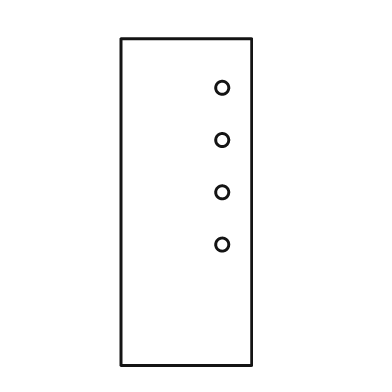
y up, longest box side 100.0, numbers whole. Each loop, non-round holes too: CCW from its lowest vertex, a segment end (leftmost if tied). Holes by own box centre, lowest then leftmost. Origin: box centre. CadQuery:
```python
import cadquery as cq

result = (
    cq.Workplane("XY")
    .moveTo(-20.0, -50.0)
    .lineTo(20.0, -50.0)
    .lineTo(20.0, 50.0)
    .lineTo(-20.0, 50.0)
    .close()
    .moveTo(11.0, -13.0)
    .circle(2.0)
    .moveTo(11.0, 3.0)
    .circle(2.0)
    .moveTo(11.0, 19.0)
    .circle(2.0)
    .moveTo(11.0, 35.0)
    .circle(2.0)
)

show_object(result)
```